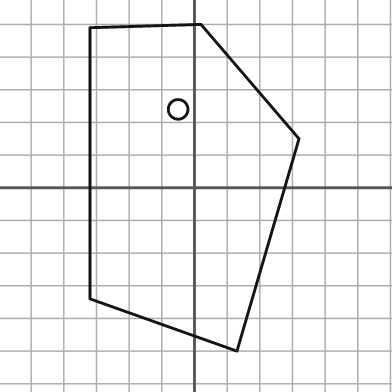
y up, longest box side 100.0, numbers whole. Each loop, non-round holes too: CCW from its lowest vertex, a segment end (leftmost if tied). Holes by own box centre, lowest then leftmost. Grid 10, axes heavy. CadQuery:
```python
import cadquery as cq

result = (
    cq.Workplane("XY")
    .moveTo(13.0, -50.0)
    .lineTo(32.0, 15.0)
    .lineTo(2.0, 50.0)
    .lineTo(-32.0, 49.0)
    .lineTo(-32.0, -34.0)
    .close()
    .moveTo(-5.0, 24.0)
    .circle(3.0)
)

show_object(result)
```